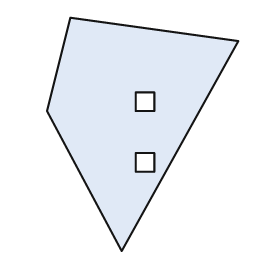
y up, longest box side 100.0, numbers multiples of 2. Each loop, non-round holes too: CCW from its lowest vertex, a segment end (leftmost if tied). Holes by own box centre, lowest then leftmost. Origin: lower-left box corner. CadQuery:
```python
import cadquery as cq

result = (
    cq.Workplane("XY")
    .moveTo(32.0, 0.0)
    .lineTo(82.0, 90.0)
    .lineTo(10.0, 100.0)
    .lineTo(0.0, 60.0)
    .close()
    .moveTo(38.0, 34.0)
    .lineTo(46.0, 34.0)
    .lineTo(46.0, 42.0)
    .lineTo(38.0, 42.0)
    .close()
    .moveTo(38.0, 60.0)
    .lineTo(46.0, 60.0)
    .lineTo(46.0, 68.0)
    .lineTo(38.0, 68.0)
    .close()
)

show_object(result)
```